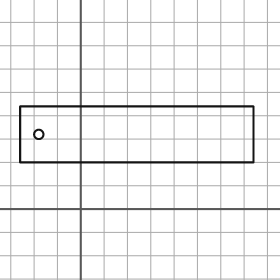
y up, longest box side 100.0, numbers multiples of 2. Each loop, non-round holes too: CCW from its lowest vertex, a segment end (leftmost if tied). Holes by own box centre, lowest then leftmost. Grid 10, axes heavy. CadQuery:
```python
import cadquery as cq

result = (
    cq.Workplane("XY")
    .moveTo(-26.0, 20.0)
    .lineTo(74.0, 20.0)
    .lineTo(74.0, 44.0)
    .lineTo(-26.0, 44.0)
    .close()
    .moveTo(-18.0, 32.0)
    .circle(2.0)
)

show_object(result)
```